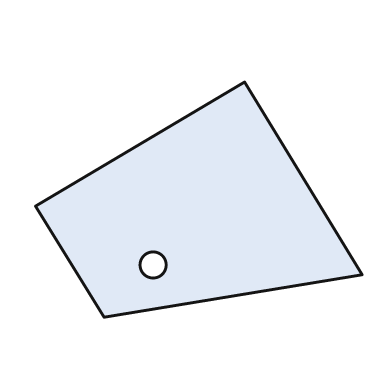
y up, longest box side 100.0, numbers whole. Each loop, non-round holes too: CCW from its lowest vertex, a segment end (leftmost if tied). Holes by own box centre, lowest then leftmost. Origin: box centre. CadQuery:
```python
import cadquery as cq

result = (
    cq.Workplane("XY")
    .moveTo(-29.0, -36.0)
    .lineTo(50.0, -23.0)
    .lineTo(14.0, 36.0)
    .lineTo(-50.0, -2.0)
    .close()
    .moveTo(-14.0, -20.0)
    .circle(4.0)
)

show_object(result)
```